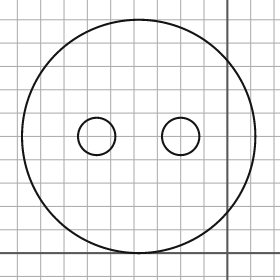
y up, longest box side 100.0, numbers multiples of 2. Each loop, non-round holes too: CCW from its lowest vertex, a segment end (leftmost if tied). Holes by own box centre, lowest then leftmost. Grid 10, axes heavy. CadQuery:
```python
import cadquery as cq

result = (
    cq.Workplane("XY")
    .moveTo(-38.0, 50.0)
    .circle(50.0)
    .moveTo(-56.0, 50.0)
    .circle(8.0)
    .moveTo(-20.0, 50.0)
    .circle(8.0)
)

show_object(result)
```